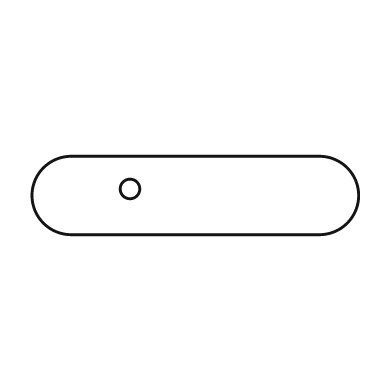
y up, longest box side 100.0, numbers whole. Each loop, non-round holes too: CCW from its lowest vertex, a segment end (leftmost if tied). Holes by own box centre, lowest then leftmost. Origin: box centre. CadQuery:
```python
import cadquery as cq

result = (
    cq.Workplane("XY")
    .moveTo(-38.0, -12.0)
    .lineTo(38.0, -12.0)
    .threePointArc((50.0, 0.0), (38.0, 12.0))
    .lineTo(-38.0, 12.0)
    .threePointArc((-50.0, 0.0), (-38.0, -12.0))
    .close()
    .moveTo(-20.0, 2.0)
    .circle(3.0)
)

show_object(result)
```